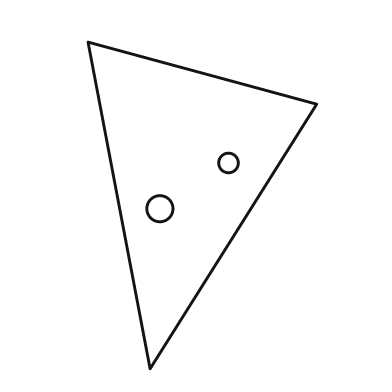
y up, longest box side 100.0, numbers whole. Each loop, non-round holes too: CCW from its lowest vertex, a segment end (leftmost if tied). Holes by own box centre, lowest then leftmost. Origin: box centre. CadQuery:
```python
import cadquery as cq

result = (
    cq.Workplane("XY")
    .moveTo(-16.0, -50.0)
    .lineTo(35.0, 31.0)
    .lineTo(-35.0, 50.0)
    .close()
    .moveTo(-13.0, -1.0)
    .circle(4.0)
    .moveTo(8.0, 13.0)
    .circle(3.0)
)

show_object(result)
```